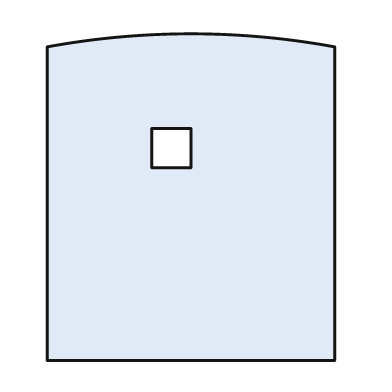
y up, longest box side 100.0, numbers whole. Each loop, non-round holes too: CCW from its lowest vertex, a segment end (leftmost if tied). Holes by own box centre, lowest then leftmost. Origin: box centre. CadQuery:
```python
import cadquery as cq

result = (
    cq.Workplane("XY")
    .moveTo(-44.0, -50.0)
    .lineTo(44.0, -50.0)
    .lineTo(44.0, 46.0)
    .threePointArc((0.0, 50.0), (-44.0, 46.0))
    .close()
    .moveTo(-12.0, 9.0)
    .lineTo(0.0, 9.0)
    .lineTo(0.0, 21.0)
    .lineTo(-12.0, 21.0)
    .close()
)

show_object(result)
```